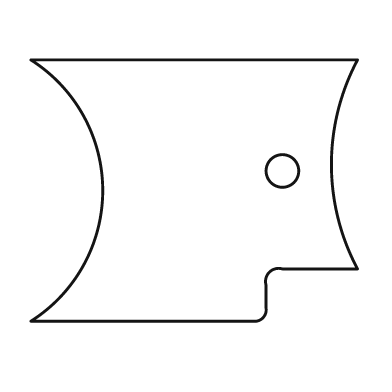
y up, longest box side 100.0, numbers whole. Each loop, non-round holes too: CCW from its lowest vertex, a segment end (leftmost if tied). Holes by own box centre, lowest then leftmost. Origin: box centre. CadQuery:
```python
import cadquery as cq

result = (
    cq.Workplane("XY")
    .moveTo(-50.0, -40.0)
    .lineTo(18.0, -40.0)
    .threePointArc((21.0, -39.0), (22.0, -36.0))
    .lineTo(22.0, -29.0)
    .threePointArc((23.0, -25.0), (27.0, -24.0))
    .lineTo(50.0, -24.0)
    .threePointArc((42.0, 8.0), (50.0, 40.0))
    .lineTo(-50.0, 40.0)
    .threePointArc((-28.0, 0.0), (-50.0, -40.0))
    .close()
    .moveTo(27.0, 6.0)
    .circle(5.0)
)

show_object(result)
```